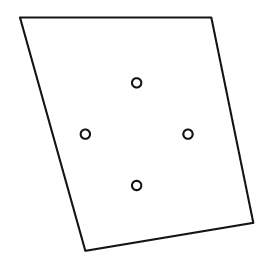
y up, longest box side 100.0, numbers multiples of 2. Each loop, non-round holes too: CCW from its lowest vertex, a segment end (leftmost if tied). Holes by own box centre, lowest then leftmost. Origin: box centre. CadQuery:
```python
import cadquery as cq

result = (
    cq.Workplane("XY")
    .moveTo(-22.0, -50.0)
    .lineTo(50.0, -38.0)
    .lineTo(32.0, 50.0)
    .lineTo(-50.0, 50.0)
    .close()
    .moveTo(0.0, -22.0)
    .circle(2.0)
    .moveTo(-22.0, 0.0)
    .circle(2.0)
    .moveTo(22.0, 0.0)
    .circle(2.0)
    .moveTo(0.0, 22.0)
    .circle(2.0)
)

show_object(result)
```